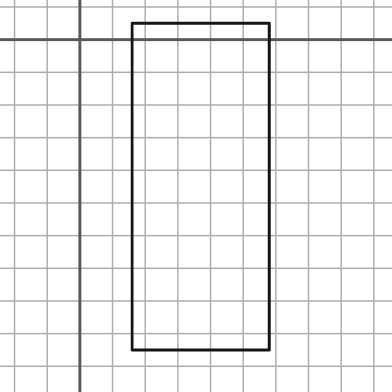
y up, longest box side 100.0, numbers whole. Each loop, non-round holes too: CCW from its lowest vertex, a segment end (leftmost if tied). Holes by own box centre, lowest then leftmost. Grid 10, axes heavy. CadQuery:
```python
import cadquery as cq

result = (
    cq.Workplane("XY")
    .moveTo(16.0, -95.0)
    .lineTo(58.0, -95.0)
    .lineTo(58.0, 5.0)
    .lineTo(16.0, 5.0)
    .close()
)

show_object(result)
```